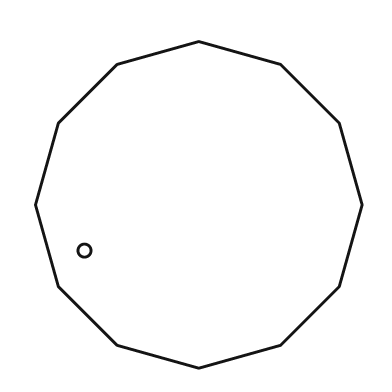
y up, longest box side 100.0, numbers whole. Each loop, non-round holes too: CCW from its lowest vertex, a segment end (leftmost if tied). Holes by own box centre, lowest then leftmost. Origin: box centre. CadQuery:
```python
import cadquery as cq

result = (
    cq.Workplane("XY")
    .moveTo(0.0, -50.0)
    .lineTo(25.0, -43.0)
    .lineTo(43.0, -25.0)
    .lineTo(50.0, 0.0)
    .lineTo(43.0, 25.0)
    .lineTo(25.0, 43.0)
    .lineTo(0.0, 50.0)
    .lineTo(-25.0, 43.0)
    .lineTo(-43.0, 25.0)
    .lineTo(-50.0, 0.0)
    .lineTo(-43.0, -25.0)
    .lineTo(-25.0, -43.0)
    .close()
    .moveTo(-35.0, -14.0)
    .circle(2.0)
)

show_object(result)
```